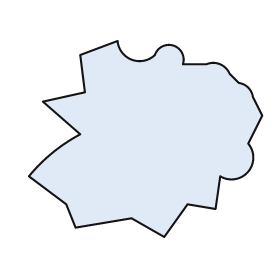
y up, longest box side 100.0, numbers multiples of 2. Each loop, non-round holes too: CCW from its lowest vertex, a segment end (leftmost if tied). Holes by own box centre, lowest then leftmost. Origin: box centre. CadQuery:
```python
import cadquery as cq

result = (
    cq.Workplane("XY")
    .moveTo(8.0, -42.0)
    .lineTo(18.0, -28.0)
    .lineTo(30.0, -30.0)
    .lineTo(32.0, -16.0)
    .threePointArc((44.0, -14.0), (44.0, -2.0))
    .lineTo(50.0, 10.0)
    .lineTo(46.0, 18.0)
    .threePointArc((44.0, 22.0), (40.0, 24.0))
    .lineTo(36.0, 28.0)
    .threePointArc((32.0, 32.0), (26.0, 32.0))
    .lineTo(16.0, 32.0)
    .threePointArc((12.0, 40.0), (4.0, 36.0))
    .threePointArc((-6.0, 34.0), (-12.0, 42.0))
    .lineTo(-28.0, 36.0)
    .lineTo(-26.0, 20.0)
    .lineTo(-44.0, 16.0)
    .lineTo(-28.0, 2.0)
    .threePointArc((-40.0, -6.0), (-50.0, -16.0))
    .lineTo(-34.0, -28.0)
    .lineTo(-30.0, -38.0)
    .lineTo(-6.0, -34.0)
    .close()
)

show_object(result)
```